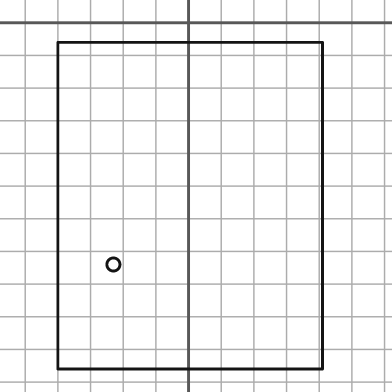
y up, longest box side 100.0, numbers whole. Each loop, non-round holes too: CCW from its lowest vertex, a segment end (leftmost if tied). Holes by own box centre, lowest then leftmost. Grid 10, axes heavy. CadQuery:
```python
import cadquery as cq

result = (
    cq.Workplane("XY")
    .moveTo(-40.0, -106.0)
    .lineTo(41.0, -106.0)
    .lineTo(41.0, -6.0)
    .lineTo(-40.0, -6.0)
    .close()
    .moveTo(-23.0, -74.0)
    .circle(2.0)
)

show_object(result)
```